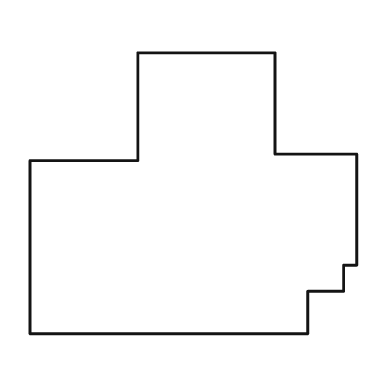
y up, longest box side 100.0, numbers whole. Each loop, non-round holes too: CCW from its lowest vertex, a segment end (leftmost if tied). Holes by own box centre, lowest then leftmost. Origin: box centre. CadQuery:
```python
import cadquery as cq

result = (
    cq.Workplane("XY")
    .moveTo(-50.0, -43.0)
    .lineTo(35.0, -43.0)
    .lineTo(35.0, -30.0)
    .lineTo(46.0, -30.0)
    .lineTo(46.0, -22.0)
    .lineTo(50.0, -22.0)
    .lineTo(50.0, 12.0)
    .lineTo(25.0, 12.0)
    .lineTo(25.0, 43.0)
    .lineTo(-17.0, 43.0)
    .lineTo(-17.0, 10.0)
    .lineTo(-50.0, 10.0)
    .close()
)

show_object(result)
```